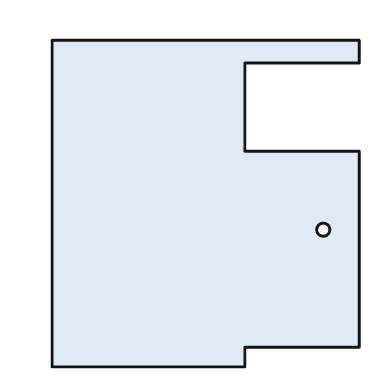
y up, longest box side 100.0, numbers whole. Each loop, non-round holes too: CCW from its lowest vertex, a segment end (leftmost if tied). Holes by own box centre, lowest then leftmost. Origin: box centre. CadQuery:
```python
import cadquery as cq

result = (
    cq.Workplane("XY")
    .moveTo(-47.0, -50.0)
    .lineTo(12.0, -50.0)
    .lineTo(12.0, -44.0)
    .lineTo(47.0, -44.0)
    .lineTo(47.0, 16.0)
    .lineTo(12.0, 16.0)
    .lineTo(12.0, 43.0)
    .lineTo(47.0, 43.0)
    .lineTo(47.0, 50.0)
    .lineTo(-47.0, 50.0)
    .close()
    .moveTo(36.0, -8.0)
    .circle(2.0)
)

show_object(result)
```